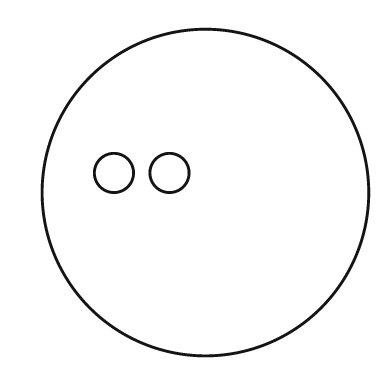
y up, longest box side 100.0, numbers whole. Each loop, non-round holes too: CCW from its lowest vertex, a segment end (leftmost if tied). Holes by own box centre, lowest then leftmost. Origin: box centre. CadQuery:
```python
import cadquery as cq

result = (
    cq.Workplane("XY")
    .moveTo(0.0, 0.0)
    .circle(50.0)
    .moveTo(-28.0, 6.0)
    .circle(6.0)
    .moveTo(-11.0, 6.0)
    .circle(6.0)
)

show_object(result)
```